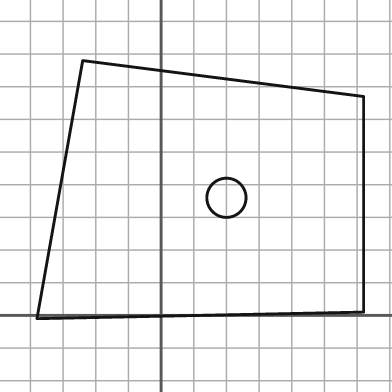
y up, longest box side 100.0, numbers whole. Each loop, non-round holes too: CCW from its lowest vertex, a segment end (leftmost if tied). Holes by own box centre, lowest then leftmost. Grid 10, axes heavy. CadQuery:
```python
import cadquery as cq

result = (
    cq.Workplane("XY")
    .moveTo(-38.0, -1.0)
    .lineTo(62.0, 1.0)
    .lineTo(62.0, 67.0)
    .lineTo(-24.0, 78.0)
    .close()
    .moveTo(20.0, 36.0)
    .circle(6.0)
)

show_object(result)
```